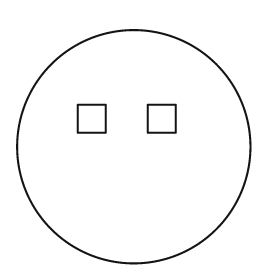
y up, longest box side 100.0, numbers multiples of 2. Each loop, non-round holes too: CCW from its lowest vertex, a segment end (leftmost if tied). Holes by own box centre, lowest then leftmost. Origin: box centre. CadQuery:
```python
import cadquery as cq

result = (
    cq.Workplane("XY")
    .moveTo(0.0, 0.0)
    .circle(50.0)
    .moveTo(-24.0, 6.0)
    .lineTo(-12.0, 6.0)
    .lineTo(-12.0, 18.0)
    .lineTo(-24.0, 18.0)
    .close()
    .moveTo(6.0, 6.0)
    .lineTo(18.0, 6.0)
    .lineTo(18.0, 18.0)
    .lineTo(6.0, 18.0)
    .close()
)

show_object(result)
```